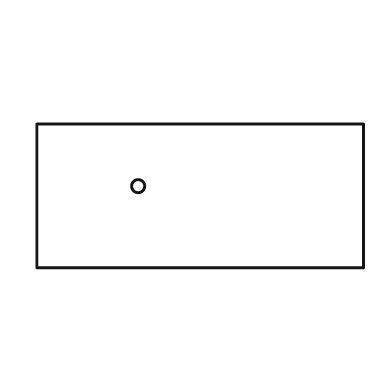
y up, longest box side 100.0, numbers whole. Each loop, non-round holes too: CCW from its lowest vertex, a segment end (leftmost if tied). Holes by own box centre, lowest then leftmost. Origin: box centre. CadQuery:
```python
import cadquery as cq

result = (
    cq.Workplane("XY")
    .moveTo(-50.0, -22.0)
    .lineTo(50.0, -22.0)
    .lineTo(50.0, 22.0)
    .lineTo(-50.0, 22.0)
    .close()
    .moveTo(-19.0, 3.0)
    .circle(2.0)
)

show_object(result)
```